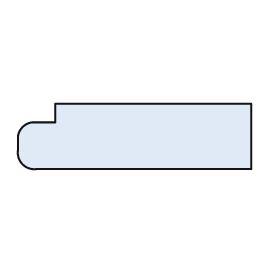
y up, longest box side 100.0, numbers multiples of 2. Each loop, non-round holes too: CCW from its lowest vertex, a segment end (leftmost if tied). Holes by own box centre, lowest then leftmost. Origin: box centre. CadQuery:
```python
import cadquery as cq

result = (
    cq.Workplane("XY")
    .moveTo(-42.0, -14.0)
    .lineTo(50.0, -14.0)
    .lineTo(50.0, 14.0)
    .lineTo(-34.0, 14.0)
    .lineTo(-34.0, 6.0)
    .lineTo(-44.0, 6.0)
    .threePointArc((-48.0, 4.0), (-50.0, 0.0))
    .lineTo(-50.0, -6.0)
    .threePointArc((-48.0, -12.0), (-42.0, -14.0))
    .close()
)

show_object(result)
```